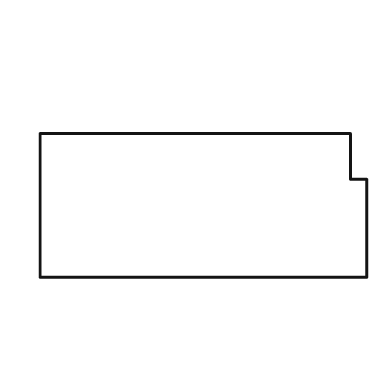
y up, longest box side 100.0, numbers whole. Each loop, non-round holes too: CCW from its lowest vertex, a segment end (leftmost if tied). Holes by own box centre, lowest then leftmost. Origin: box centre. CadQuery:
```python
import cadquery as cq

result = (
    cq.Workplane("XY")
    .moveTo(-50.0, -22.0)
    .lineTo(50.0, -22.0)
    .lineTo(50.0, 8.0)
    .lineTo(45.0, 8.0)
    .lineTo(45.0, 22.0)
    .lineTo(-50.0, 22.0)
    .close()
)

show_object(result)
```